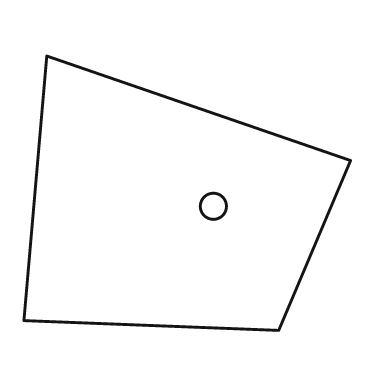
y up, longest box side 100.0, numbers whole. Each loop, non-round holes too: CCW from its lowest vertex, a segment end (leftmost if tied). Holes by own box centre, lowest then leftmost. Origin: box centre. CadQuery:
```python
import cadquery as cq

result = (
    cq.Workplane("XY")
    .moveTo(28.0, -42.0)
    .lineTo(50.0, 10.0)
    .lineTo(-43.0, 42.0)
    .lineTo(-50.0, -39.0)
    .close()
    .moveTo(8.0, -4.0)
    .circle(4.0)
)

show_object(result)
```